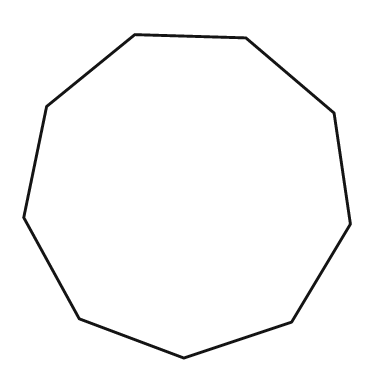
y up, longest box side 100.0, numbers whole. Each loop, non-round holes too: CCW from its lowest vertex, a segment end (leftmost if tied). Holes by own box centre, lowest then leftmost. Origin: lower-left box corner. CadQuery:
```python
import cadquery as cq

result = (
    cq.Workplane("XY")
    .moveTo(49.0, 0.0)
    .lineTo(82.0, 11.0)
    .lineTo(100.0, 41.0)
    .lineTo(95.0, 75.0)
    .lineTo(68.0, 98.0)
    .lineTo(34.0, 99.0)
    .lineTo(7.0, 77.0)
    .lineTo(0.0, 43.0)
    .lineTo(17.0, 12.0)
    .close()
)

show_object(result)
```